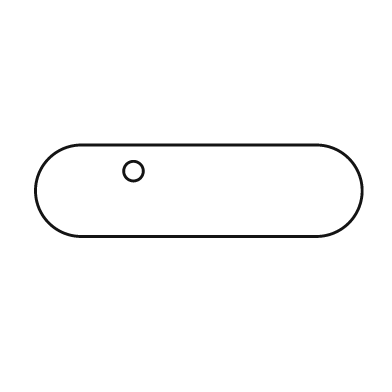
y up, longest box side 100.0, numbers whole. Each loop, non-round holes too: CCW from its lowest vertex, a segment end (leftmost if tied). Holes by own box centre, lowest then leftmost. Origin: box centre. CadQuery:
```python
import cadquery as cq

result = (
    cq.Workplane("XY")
    .moveTo(-36.0, -14.0)
    .lineTo(36.0, -14.0)
    .threePointArc((50.0, 0.0), (36.0, 14.0))
    .lineTo(-36.0, 14.0)
    .threePointArc((-50.0, 0.0), (-36.0, -14.0))
    .close()
    .moveTo(-20.0, 6.0)
    .circle(3.0)
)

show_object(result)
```